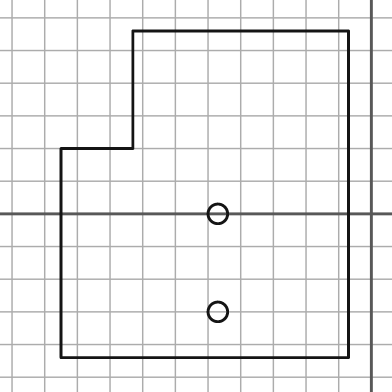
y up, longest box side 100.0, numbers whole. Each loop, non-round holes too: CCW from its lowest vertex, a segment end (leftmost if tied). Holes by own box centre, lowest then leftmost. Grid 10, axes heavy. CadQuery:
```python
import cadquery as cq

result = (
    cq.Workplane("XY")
    .moveTo(-95.0, -44.0)
    .lineTo(-7.0, -44.0)
    .lineTo(-7.0, 56.0)
    .lineTo(-73.0, 56.0)
    .lineTo(-73.0, 20.0)
    .lineTo(-95.0, 20.0)
    .close()
    .moveTo(-47.0, -30.0)
    .circle(3.0)
    .moveTo(-47.0, 0.0)
    .circle(3.0)
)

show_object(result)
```